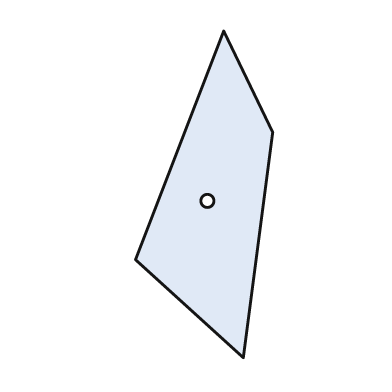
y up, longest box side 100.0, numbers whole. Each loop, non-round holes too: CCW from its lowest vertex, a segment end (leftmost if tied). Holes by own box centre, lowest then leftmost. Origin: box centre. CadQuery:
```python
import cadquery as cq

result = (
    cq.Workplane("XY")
    .moveTo(12.0, -50.0)
    .lineTo(21.0, 19.0)
    .lineTo(6.0, 50.0)
    .lineTo(-21.0, -20.0)
    .close()
    .moveTo(1.0, -2.0)
    .circle(2.0)
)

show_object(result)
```